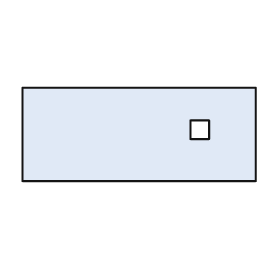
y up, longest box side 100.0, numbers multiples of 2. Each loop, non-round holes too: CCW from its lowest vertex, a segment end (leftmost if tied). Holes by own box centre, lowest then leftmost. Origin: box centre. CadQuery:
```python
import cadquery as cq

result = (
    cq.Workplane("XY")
    .moveTo(-50.0, -20.0)
    .lineTo(50.0, -20.0)
    .lineTo(50.0, 20.0)
    .lineTo(-50.0, 20.0)
    .close()
    .moveTo(22.0, -2.0)
    .lineTo(30.0, -2.0)
    .lineTo(30.0, 6.0)
    .lineTo(22.0, 6.0)
    .close()
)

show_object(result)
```